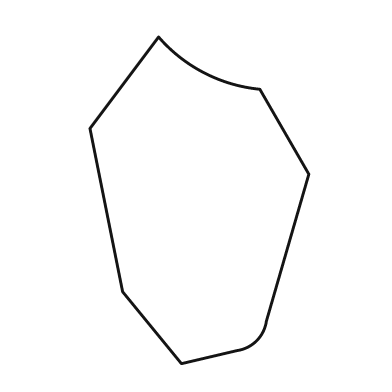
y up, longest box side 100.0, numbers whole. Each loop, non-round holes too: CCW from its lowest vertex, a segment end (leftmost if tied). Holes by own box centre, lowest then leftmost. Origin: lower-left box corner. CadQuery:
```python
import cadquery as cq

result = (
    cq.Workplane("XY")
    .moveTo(28.0, 0.0)
    .lineTo(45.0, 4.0)
    .threePointArc((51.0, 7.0), (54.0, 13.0))
    .lineTo(67.0, 58.0)
    .lineTo(52.0, 84.0)
    .threePointArc((35.0, 89.0), (21.0, 100.0))
    .lineTo(0.0, 72.0)
    .lineTo(10.0, 22.0)
    .close()
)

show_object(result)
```